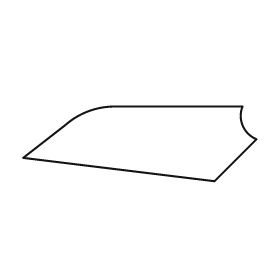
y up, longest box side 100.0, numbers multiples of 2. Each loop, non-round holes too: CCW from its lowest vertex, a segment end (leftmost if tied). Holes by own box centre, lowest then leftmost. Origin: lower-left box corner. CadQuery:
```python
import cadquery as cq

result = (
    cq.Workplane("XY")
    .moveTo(82.0, 0.0)
    .lineTo(100.0, 18.0)
    .threePointArc((94.0, 24.0), (94.0, 32.0))
    .lineTo(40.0, 32.0)
    .threePointArc((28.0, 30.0), (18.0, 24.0))
    .lineTo(0.0, 10.0)
    .close()
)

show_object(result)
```